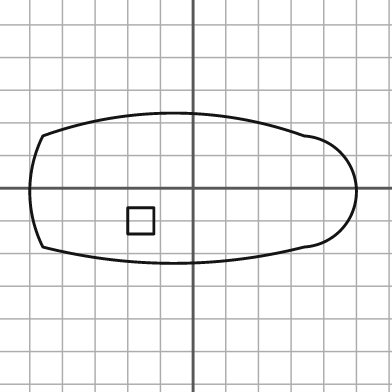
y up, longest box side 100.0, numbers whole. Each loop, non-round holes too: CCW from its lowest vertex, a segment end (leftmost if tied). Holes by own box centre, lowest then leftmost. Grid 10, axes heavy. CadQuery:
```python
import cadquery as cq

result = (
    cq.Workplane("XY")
    .moveTo(-46.0, -18.0)
    .threePointArc((-6.0, -23.0), (34.0, -18.0))
    .threePointArc((50.0, -1.0), (34.0, 16.0))
    .threePointArc((-6.0, 23.0), (-46.0, 16.0))
    .threePointArc((-50.0, -1.0), (-46.0, -18.0))
    .close()
    .moveTo(-20.0, -14.0)
    .lineTo(-12.0, -14.0)
    .lineTo(-12.0, -6.0)
    .lineTo(-20.0, -6.0)
    .close()
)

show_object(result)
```